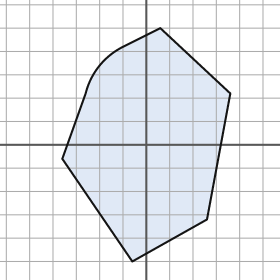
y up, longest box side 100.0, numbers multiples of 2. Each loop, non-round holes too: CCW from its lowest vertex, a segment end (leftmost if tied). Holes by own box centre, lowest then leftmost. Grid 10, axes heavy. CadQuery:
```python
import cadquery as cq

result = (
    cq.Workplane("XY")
    .moveTo(-6.0, -50.0)
    .lineTo(26.0, -32.0)
    .lineTo(36.0, 22.0)
    .lineTo(6.0, 50.0)
    .lineTo(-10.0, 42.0)
    .threePointArc((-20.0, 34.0), (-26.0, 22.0))
    .lineTo(-36.0, -6.0)
    .close()
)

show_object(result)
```